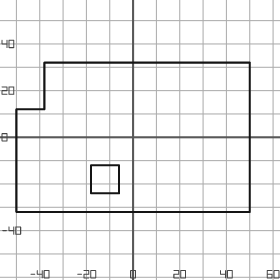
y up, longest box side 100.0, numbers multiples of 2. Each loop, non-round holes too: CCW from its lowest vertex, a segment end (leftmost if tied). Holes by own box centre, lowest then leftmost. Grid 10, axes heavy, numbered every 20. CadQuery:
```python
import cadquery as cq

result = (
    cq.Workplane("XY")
    .moveTo(-50.0, -32.0)
    .lineTo(50.0, -32.0)
    .lineTo(50.0, 32.0)
    .lineTo(-38.0, 32.0)
    .lineTo(-38.0, 12.0)
    .lineTo(-50.0, 12.0)
    .close()
    .moveTo(-18.0, -24.0)
    .lineTo(-6.0, -24.0)
    .lineTo(-6.0, -12.0)
    .lineTo(-18.0, -12.0)
    .close()
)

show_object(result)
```